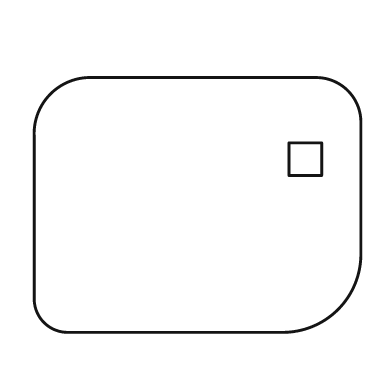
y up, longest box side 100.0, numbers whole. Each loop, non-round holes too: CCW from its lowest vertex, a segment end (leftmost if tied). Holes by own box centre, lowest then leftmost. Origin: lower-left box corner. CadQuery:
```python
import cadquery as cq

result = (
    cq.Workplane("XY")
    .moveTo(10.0, 0.0)
    .lineTo(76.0, 0.0)
    .threePointArc((93.0, 7.0), (100.0, 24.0))
    .lineTo(100.0, 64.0)
    .threePointArc((96.0, 74.0), (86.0, 78.0))
    .lineTo(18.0, 78.0)
    .threePointArc((5.0, 73.0), (0.0, 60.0))
    .lineTo(0.0, 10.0)
    .threePointArc((3.0, 3.0), (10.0, 0.0))
    .close()
    .moveTo(78.0, 48.0)
    .lineTo(88.0, 48.0)
    .lineTo(88.0, 58.0)
    .lineTo(78.0, 58.0)
    .close()
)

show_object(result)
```